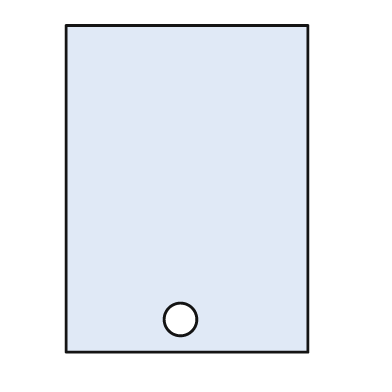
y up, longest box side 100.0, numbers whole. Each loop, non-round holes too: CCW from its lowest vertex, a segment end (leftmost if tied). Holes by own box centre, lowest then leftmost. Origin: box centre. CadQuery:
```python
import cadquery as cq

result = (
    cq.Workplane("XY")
    .moveTo(-37.0, -50.0)
    .lineTo(37.0, -50.0)
    .lineTo(37.0, 50.0)
    .lineTo(-37.0, 50.0)
    .close()
    .moveTo(-2.0, -40.0)
    .circle(5.0)
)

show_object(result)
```